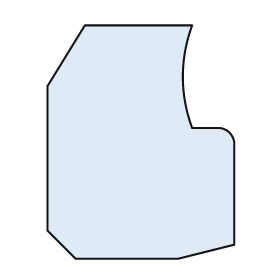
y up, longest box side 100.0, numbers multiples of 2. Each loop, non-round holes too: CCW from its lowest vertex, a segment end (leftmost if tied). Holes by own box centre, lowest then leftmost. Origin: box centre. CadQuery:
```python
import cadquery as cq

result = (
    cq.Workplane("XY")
    .moveTo(-28.0, -50.0)
    .lineTo(16.0, -50.0)
    .lineTo(40.0, -44.0)
    .lineTo(40.0, 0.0)
    .threePointArc((38.0, 4.0), (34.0, 6.0))
    .lineTo(22.0, 6.0)
    .threePointArc((18.0, 28.0), (22.0, 50.0))
    .lineTo(-24.0, 50.0)
    .lineTo(-40.0, 24.0)
    .lineTo(-40.0, -38.0)
    .close()
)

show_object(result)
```